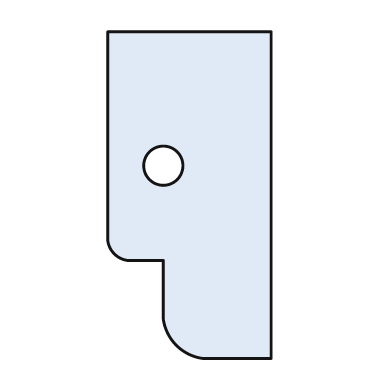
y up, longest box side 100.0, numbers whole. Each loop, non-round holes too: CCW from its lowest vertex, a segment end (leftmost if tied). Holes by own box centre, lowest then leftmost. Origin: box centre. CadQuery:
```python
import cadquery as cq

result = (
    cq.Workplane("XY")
    .moveTo(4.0, -50.0)
    .lineTo(25.0, -50.0)
    .lineTo(25.0, 50.0)
    .lineTo(-25.0, 50.0)
    .lineTo(-25.0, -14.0)
    .threePointArc((-23.0, -18.0), (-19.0, -20.0))
    .lineTo(-8.0, -20.0)
    .lineTo(-8.0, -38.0)
    .threePointArc((-4.0, -46.0), (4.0, -50.0))
    .close()
    .moveTo(-8.0, 9.0)
    .circle(6.0)
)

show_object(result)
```